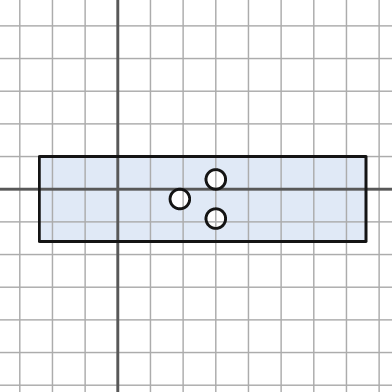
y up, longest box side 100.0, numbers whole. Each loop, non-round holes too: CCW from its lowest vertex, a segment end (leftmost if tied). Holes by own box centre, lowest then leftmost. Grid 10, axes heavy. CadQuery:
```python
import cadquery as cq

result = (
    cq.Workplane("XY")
    .moveTo(-24.0, -16.0)
    .lineTo(76.0, -16.0)
    .lineTo(76.0, 10.0)
    .lineTo(-24.0, 10.0)
    .close()
    .moveTo(30.0, -9.0)
    .circle(3.0)
    .moveTo(19.0, -3.0)
    .circle(3.0)
    .moveTo(30.0, 3.0)
    .circle(3.0)
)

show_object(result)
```